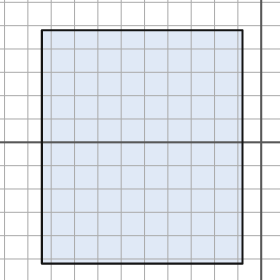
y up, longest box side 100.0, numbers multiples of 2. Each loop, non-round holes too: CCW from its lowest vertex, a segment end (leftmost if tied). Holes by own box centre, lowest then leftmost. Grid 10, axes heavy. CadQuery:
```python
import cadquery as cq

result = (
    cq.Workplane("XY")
    .moveTo(-94.0, -52.0)
    .lineTo(-8.0, -52.0)
    .lineTo(-8.0, 48.0)
    .lineTo(-94.0, 48.0)
    .close()
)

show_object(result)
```